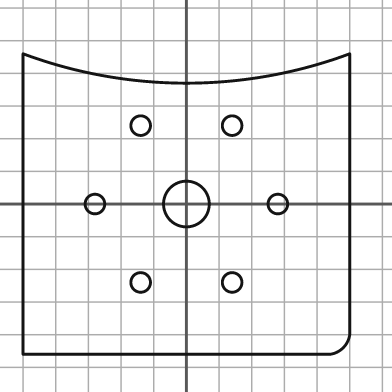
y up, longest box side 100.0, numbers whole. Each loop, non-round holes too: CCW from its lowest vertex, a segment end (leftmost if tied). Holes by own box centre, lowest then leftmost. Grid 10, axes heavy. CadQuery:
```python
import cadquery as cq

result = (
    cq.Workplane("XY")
    .moveTo(-50.0, -46.0)
    .lineTo(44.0, -46.0)
    .threePointArc((48.0, -44.0), (50.0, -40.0))
    .lineTo(50.0, 46.0)
    .threePointArc((0.0, 37.0), (-50.0, 46.0))
    .close()
    .moveTo(-14.0, -24.0)
    .circle(3.0)
    .moveTo(14.0, -24.0)
    .circle(3.0)
    .moveTo(-28.0, 0.0)
    .circle(3.0)
    .moveTo(0.0, 0.0)
    .circle(7.0)
    .moveTo(28.0, 0.0)
    .circle(3.0)
    .moveTo(-14.0, 24.0)
    .circle(3.0)
    .moveTo(14.0, 24.0)
    .circle(3.0)
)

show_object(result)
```